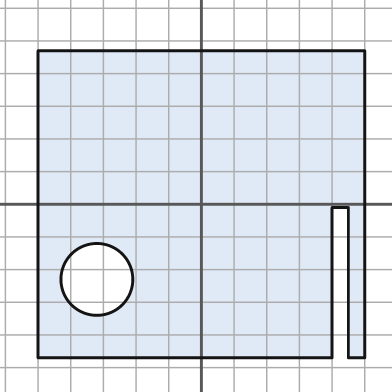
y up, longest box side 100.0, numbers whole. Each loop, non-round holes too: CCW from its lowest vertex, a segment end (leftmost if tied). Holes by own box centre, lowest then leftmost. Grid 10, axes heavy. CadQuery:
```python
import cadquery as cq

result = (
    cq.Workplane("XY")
    .moveTo(-50.0, -47.0)
    .lineTo(40.0, -47.0)
    .lineTo(40.0, -1.0)
    .lineTo(45.0, -1.0)
    .lineTo(45.0, -47.0)
    .lineTo(50.0, -47.0)
    .lineTo(50.0, 47.0)
    .lineTo(-50.0, 47.0)
    .close()
    .moveTo(-32.0, -23.0)
    .circle(11.0)
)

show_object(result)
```